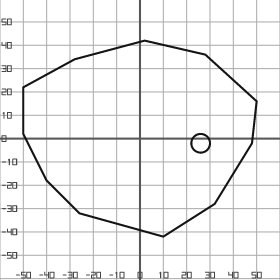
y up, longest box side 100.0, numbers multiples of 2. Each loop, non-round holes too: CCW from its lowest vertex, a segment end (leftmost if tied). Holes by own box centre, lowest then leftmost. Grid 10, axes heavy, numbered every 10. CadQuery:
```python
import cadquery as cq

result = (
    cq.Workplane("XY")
    .moveTo(10.0, -42.0)
    .lineTo(32.0, -28.0)
    .lineTo(48.0, -2.0)
    .lineTo(50.0, 16.0)
    .lineTo(28.0, 36.0)
    .lineTo(2.0, 42.0)
    .lineTo(-28.0, 34.0)
    .lineTo(-50.0, 22.0)
    .lineTo(-50.0, 2.0)
    .lineTo(-40.0, -18.0)
    .lineTo(-26.0, -32.0)
    .close()
    .moveTo(26.0, -2.0)
    .circle(4.0)
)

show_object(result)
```